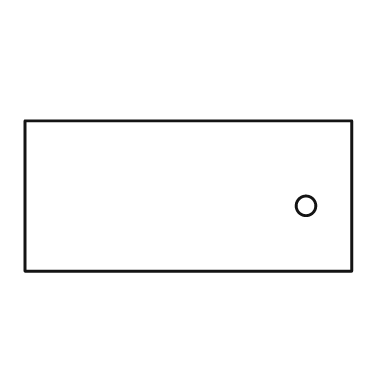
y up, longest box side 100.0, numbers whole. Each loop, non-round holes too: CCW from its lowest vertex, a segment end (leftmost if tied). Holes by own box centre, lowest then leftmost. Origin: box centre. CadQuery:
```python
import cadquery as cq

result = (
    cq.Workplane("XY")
    .moveTo(-50.0, -23.0)
    .lineTo(50.0, -23.0)
    .lineTo(50.0, 23.0)
    .lineTo(-50.0, 23.0)
    .close()
    .moveTo(36.0, -3.0)
    .circle(3.0)
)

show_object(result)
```